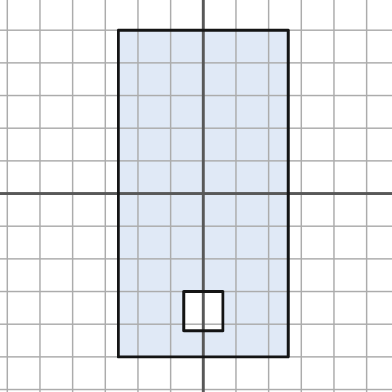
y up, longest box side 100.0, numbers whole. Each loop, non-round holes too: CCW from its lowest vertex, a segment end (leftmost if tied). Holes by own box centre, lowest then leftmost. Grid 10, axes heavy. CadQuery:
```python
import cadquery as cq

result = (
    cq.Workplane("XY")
    .moveTo(-26.0, -50.0)
    .lineTo(26.0, -50.0)
    .lineTo(26.0, 50.0)
    .lineTo(-26.0, 50.0)
    .close()
    .moveTo(-6.0, -42.0)
    .lineTo(6.0, -42.0)
    .lineTo(6.0, -30.0)
    .lineTo(-6.0, -30.0)
    .close()
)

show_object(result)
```